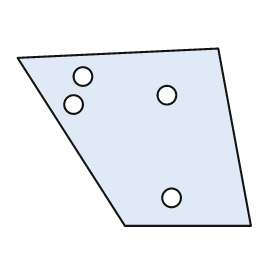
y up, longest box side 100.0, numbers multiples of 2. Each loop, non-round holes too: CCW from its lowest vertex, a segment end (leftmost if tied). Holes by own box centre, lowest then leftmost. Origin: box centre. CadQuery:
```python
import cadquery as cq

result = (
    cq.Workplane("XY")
    .moveTo(-4.0, -38.0)
    .lineTo(50.0, -38.0)
    .lineTo(36.0, 38.0)
    .lineTo(-50.0, 34.0)
    .close()
    .moveTo(16.0, -26.0)
    .circle(4.0)
    .moveTo(-26.0, 14.0)
    .circle(4.0)
    .moveTo(14.0, 18.0)
    .circle(4.0)
    .moveTo(-22.0, 26.0)
    .circle(4.0)
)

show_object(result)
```